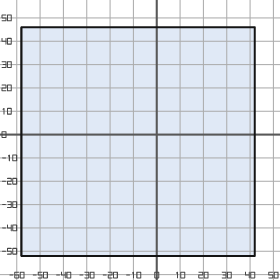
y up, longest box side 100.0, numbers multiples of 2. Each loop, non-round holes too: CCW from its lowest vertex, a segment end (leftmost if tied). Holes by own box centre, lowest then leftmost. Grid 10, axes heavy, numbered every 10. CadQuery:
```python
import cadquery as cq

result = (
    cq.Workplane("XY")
    .moveTo(-58.0, -52.0)
    .lineTo(42.0, -52.0)
    .lineTo(42.0, 46.0)
    .lineTo(-58.0, 46.0)
    .close()
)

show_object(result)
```